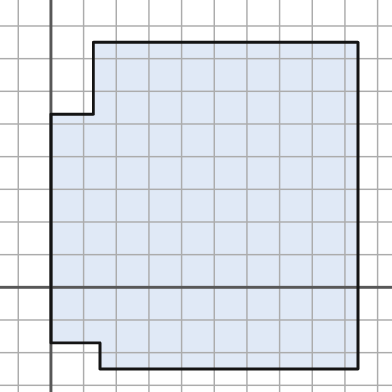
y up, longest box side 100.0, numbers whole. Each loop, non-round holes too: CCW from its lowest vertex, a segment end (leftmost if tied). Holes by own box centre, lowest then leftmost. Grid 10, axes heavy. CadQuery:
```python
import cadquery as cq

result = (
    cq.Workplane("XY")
    .moveTo(15.0, -25.0)
    .lineTo(94.0, -25.0)
    .lineTo(94.0, 75.0)
    .lineTo(13.0, 75.0)
    .lineTo(13.0, 53.0)
    .lineTo(0.0, 53.0)
    .lineTo(0.0, -17.0)
    .lineTo(15.0, -17.0)
    .close()
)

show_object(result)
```